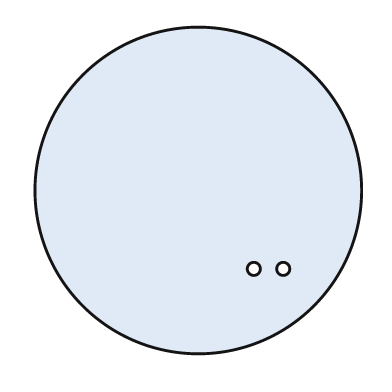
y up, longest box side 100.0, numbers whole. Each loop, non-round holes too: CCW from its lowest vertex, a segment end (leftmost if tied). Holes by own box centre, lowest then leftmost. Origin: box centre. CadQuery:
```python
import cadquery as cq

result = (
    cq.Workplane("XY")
    .moveTo(0.0, 0.0)
    .circle(50.0)
    .moveTo(17.0, -24.0)
    .circle(2.0)
    .moveTo(26.0, -24.0)
    .circle(2.0)
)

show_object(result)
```